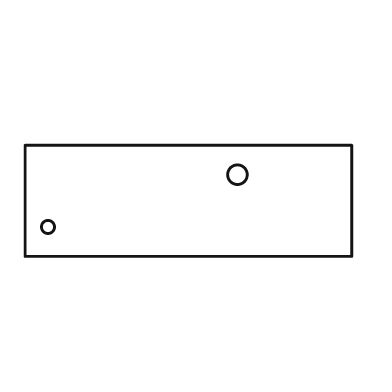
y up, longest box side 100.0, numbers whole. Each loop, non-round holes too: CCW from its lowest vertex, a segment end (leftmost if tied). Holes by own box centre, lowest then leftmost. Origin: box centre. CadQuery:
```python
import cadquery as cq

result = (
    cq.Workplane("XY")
    .moveTo(-50.0, -17.0)
    .lineTo(50.0, -17.0)
    .lineTo(50.0, 17.0)
    .lineTo(-50.0, 17.0)
    .close()
    .moveTo(-43.0, -8.0)
    .circle(2.0)
    .moveTo(15.0, 8.0)
    .circle(3.0)
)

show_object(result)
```